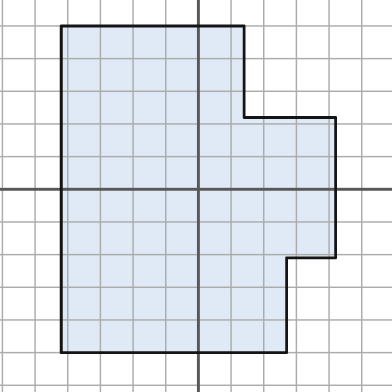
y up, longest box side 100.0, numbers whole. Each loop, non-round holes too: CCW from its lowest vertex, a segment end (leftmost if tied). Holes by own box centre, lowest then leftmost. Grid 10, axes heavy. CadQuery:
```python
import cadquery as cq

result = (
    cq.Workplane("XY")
    .moveTo(-42.0, -50.0)
    .lineTo(27.0, -50.0)
    .lineTo(27.0, -21.0)
    .lineTo(42.0, -21.0)
    .lineTo(42.0, 22.0)
    .lineTo(14.0, 22.0)
    .lineTo(14.0, 50.0)
    .lineTo(-42.0, 50.0)
    .close()
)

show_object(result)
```